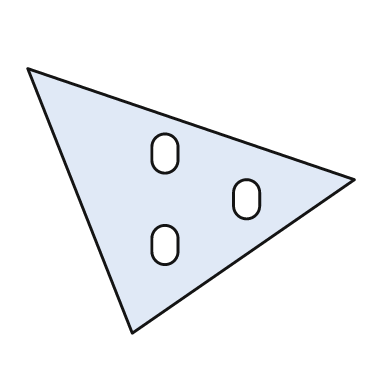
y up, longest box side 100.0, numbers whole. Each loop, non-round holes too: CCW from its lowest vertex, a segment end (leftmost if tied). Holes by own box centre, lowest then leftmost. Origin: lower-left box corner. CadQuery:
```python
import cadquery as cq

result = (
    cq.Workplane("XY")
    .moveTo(32.0, 0.0)
    .lineTo(100.0, 47.0)
    .lineTo(0.0, 81.0)
    .close()
    .moveTo(38.0, 25.0)
    .threePointArc((42.0, 21.0), (46.0, 25.0))
    .lineTo(46.0, 29.0)
    .threePointArc((42.0, 33.0), (38.0, 29.0))
    .close()
    .moveTo(63.0, 39.0)
    .threePointArc((67.0, 35.0), (71.0, 39.0))
    .lineTo(71.0, 43.0)
    .threePointArc((67.0, 47.0), (63.0, 43.0))
    .close()
    .moveTo(38.0, 53.0)
    .threePointArc((42.0, 49.0), (46.0, 53.0))
    .lineTo(46.0, 57.0)
    .threePointArc((42.0, 61.0), (38.0, 57.0))
    .close()
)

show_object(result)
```